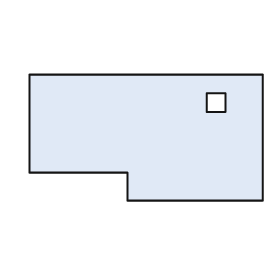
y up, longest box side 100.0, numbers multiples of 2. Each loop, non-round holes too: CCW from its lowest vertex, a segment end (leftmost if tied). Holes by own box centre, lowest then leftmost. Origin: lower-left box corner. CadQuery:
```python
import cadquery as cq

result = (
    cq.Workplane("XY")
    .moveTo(42.0, 0.0)
    .lineTo(100.0, 0.0)
    .lineTo(100.0, 54.0)
    .lineTo(0.0, 54.0)
    .lineTo(0.0, 12.0)
    .lineTo(42.0, 12.0)
    .close()
    .moveTo(76.0, 38.0)
    .lineTo(84.0, 38.0)
    .lineTo(84.0, 46.0)
    .lineTo(76.0, 46.0)
    .close()
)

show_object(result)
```